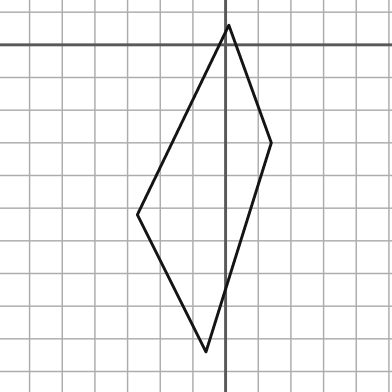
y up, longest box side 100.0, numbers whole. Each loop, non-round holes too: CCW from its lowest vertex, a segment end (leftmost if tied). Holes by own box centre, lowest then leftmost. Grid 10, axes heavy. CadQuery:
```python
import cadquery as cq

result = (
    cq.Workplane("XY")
    .moveTo(-6.0, -94.0)
    .lineTo(14.0, -30.0)
    .lineTo(1.0, 6.0)
    .lineTo(-27.0, -52.0)
    .close()
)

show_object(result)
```